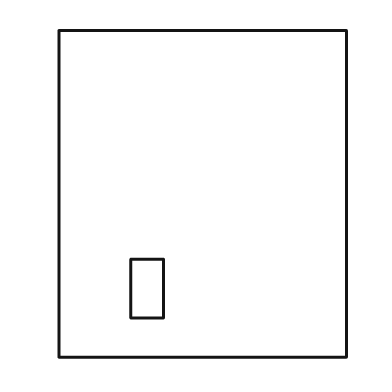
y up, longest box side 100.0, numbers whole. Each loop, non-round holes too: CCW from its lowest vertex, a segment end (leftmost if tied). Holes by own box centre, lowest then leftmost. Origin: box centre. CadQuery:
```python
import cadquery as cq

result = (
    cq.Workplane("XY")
    .moveTo(-44.0, -50.0)
    .lineTo(44.0, -50.0)
    .lineTo(44.0, 50.0)
    .lineTo(-44.0, 50.0)
    .close()
    .moveTo(-22.0, -38.0)
    .lineTo(-12.0, -38.0)
    .lineTo(-12.0, -20.0)
    .lineTo(-22.0, -20.0)
    .close()
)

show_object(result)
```